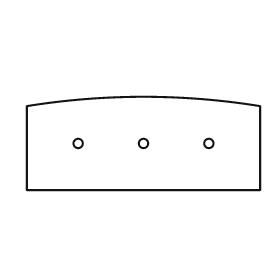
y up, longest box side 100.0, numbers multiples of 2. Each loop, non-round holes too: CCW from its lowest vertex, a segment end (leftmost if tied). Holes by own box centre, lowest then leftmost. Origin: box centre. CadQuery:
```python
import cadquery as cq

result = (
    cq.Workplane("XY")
    .moveTo(-50.0, -20.0)
    .lineTo(50.0, -20.0)
    .lineTo(50.0, 16.0)
    .threePointArc((0.0, 20.0), (-50.0, 16.0))
    .close()
    .moveTo(-28.0, 0.0)
    .circle(2.0)
    .moveTo(0.0, 0.0)
    .circle(2.0)
    .moveTo(28.0, 0.0)
    .circle(2.0)
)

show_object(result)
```